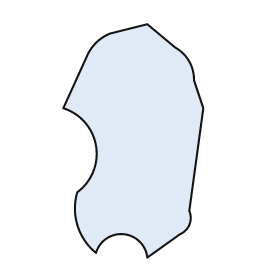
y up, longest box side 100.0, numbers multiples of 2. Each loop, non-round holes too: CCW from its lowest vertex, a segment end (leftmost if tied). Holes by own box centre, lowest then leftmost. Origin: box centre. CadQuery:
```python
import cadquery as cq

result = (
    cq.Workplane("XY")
    .moveTo(6.0, -50.0)
    .lineTo(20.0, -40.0)
    .threePointArc((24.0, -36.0), (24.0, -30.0))
    .lineTo(30.0, 14.0)
    .lineTo(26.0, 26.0)
    .threePointArc((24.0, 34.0), (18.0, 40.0))
    .lineTo(6.0, 50.0)
    .lineTo(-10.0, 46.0)
    .threePointArc((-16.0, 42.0), (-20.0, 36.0))
    .lineTo(-30.0, 14.0)
    .threePointArc((-16.0, -2.0), (-24.0, -22.0))
    .threePointArc((-24.0, -36.0), (-16.0, -48.0))
    .threePointArc((-4.0, -40.0), (6.0, -50.0))
    .close()
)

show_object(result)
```